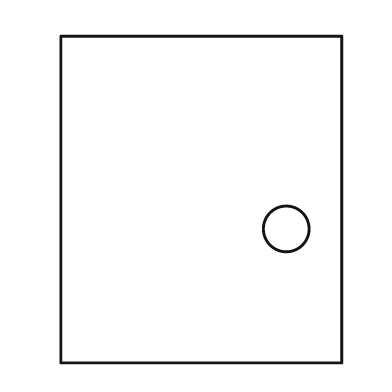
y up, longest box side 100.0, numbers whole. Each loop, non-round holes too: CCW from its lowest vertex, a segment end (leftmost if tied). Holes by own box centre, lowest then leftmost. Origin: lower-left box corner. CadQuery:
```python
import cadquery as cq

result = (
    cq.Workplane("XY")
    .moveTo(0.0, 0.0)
    .lineTo(86.0, 0.0)
    .lineTo(86.0, 100.0)
    .lineTo(0.0, 100.0)
    .close()
    .moveTo(69.0, 41.0)
    .circle(7.0)
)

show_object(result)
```